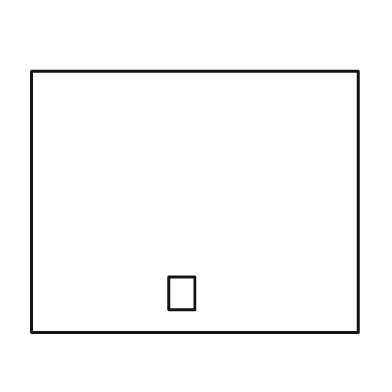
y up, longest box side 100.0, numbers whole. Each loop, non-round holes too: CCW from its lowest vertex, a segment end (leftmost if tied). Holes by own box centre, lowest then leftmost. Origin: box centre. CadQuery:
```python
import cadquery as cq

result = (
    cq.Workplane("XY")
    .moveTo(-50.0, -40.0)
    .lineTo(50.0, -40.0)
    .lineTo(50.0, 40.0)
    .lineTo(-50.0, 40.0)
    .close()
    .moveTo(-8.0, -33.0)
    .lineTo(0.0, -33.0)
    .lineTo(0.0, -23.0)
    .lineTo(-8.0, -23.0)
    .close()
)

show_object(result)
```